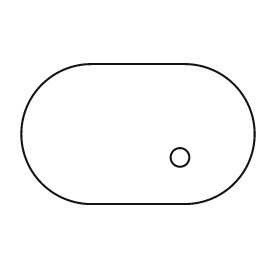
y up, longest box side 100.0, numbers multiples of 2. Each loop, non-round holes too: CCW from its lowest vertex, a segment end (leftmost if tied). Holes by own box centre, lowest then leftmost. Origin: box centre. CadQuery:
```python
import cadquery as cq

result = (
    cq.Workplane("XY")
    .moveTo(-20.0, -30.0)
    .lineTo(20.0, -30.0)
    .threePointArc((50.0, 0.0), (20.0, 30.0))
    .lineTo(-20.0, 30.0)
    .threePointArc((-50.0, 0.0), (-20.0, -30.0))
    .close()
    .moveTo(18.0, -10.0)
    .circle(4.0)
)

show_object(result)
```